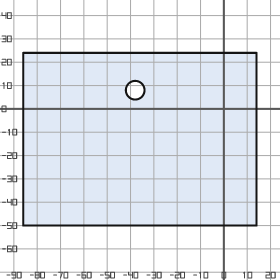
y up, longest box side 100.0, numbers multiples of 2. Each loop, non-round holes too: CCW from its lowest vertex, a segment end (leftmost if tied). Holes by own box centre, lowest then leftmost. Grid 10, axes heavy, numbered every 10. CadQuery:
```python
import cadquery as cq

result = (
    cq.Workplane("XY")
    .moveTo(-86.0, -50.0)
    .lineTo(14.0, -50.0)
    .lineTo(14.0, 24.0)
    .lineTo(-86.0, 24.0)
    .close()
    .moveTo(-38.0, 8.0)
    .circle(4.0)
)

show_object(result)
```